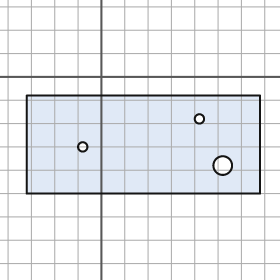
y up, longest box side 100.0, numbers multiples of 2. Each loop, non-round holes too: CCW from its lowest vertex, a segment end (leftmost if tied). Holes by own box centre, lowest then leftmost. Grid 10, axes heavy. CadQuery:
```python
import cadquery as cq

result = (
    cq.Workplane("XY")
    .moveTo(-32.0, -50.0)
    .lineTo(68.0, -50.0)
    .lineTo(68.0, -8.0)
    .lineTo(-32.0, -8.0)
    .close()
    .moveTo(52.0, -38.0)
    .circle(4.0)
    .moveTo(-8.0, -30.0)
    .circle(2.0)
    .moveTo(42.0, -18.0)
    .circle(2.0)
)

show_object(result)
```